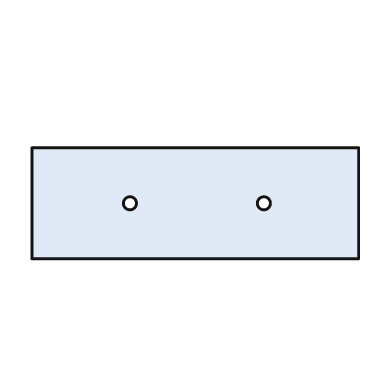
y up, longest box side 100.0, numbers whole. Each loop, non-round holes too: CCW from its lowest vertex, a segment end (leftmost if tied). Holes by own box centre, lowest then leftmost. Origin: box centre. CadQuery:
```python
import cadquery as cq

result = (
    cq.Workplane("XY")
    .moveTo(-50.0, -17.0)
    .lineTo(50.0, -17.0)
    .lineTo(50.0, 17.0)
    .lineTo(-50.0, 17.0)
    .close()
    .moveTo(-20.0, 0.0)
    .circle(2.0)
    .moveTo(21.0, 0.0)
    .circle(2.0)
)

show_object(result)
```